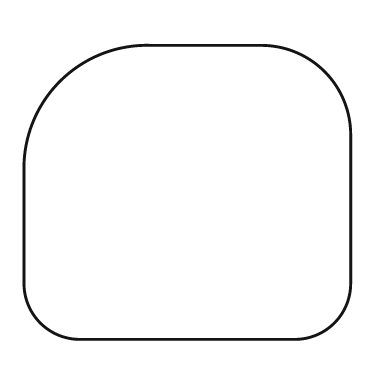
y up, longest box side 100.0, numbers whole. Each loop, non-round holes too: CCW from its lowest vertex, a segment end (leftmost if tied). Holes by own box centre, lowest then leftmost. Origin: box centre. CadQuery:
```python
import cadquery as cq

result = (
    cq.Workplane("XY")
    .moveTo(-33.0, -45.0)
    .lineTo(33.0, -45.0)
    .threePointArc((45.0, -40.0), (50.0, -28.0))
    .lineTo(50.0, 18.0)
    .threePointArc((42.0, 37.0), (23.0, 45.0))
    .lineTo(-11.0, 45.0)
    .threePointArc((-39.0, 34.0), (-50.0, 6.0))
    .lineTo(-50.0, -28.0)
    .threePointArc((-45.0, -40.0), (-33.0, -45.0))
    .close()
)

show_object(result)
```